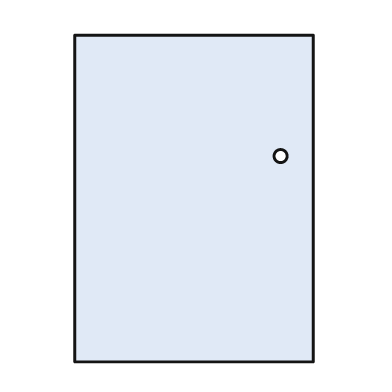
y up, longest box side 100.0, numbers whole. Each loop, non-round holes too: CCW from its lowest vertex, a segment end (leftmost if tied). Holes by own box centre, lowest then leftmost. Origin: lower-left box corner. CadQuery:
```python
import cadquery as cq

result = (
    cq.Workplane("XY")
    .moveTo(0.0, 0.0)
    .lineTo(73.0, 0.0)
    .lineTo(73.0, 100.0)
    .lineTo(0.0, 100.0)
    .close()
    .moveTo(63.0, 63.0)
    .circle(2.0)
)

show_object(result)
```